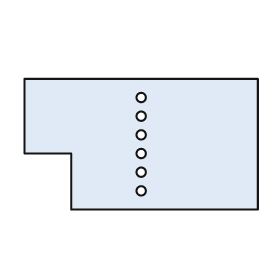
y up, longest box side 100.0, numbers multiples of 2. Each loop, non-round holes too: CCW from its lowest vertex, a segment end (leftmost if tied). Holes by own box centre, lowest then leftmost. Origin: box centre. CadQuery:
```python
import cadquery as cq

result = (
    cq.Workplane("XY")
    .moveTo(-30.0, -28.0)
    .lineTo(50.0, -28.0)
    .lineTo(50.0, 28.0)
    .lineTo(-50.0, 28.0)
    .lineTo(-50.0, -4.0)
    .lineTo(-30.0, -4.0)
    .close()
    .moveTo(0.0, -20.0)
    .circle(2.0)
    .moveTo(0.0, -12.0)
    .circle(2.0)
    .moveTo(0.0, -4.0)
    .circle(2.0)
    .moveTo(0.0, 4.0)
    .circle(2.0)
    .moveTo(0.0, 12.0)
    .circle(2.0)
    .moveTo(0.0, 20.0)
    .circle(2.0)
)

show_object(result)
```